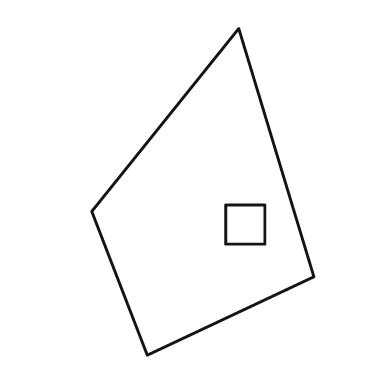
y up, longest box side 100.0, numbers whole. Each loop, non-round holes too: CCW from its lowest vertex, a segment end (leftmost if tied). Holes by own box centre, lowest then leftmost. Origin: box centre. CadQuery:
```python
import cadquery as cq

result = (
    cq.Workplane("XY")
    .moveTo(-17.0, -50.0)
    .lineTo(34.0, -26.0)
    .lineTo(11.0, 50.0)
    .lineTo(-34.0, -6.0)
    .close()
    .moveTo(7.0, -16.0)
    .lineTo(19.0, -16.0)
    .lineTo(19.0, -4.0)
    .lineTo(7.0, -4.0)
    .close()
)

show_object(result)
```